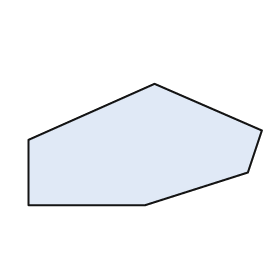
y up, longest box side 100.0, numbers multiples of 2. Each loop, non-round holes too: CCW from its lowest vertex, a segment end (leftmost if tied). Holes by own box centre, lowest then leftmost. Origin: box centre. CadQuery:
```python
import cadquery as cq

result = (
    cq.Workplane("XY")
    .moveTo(-50.0, -26.0)
    .lineTo(0.0, -26.0)
    .lineTo(44.0, -12.0)
    .lineTo(50.0, 6.0)
    .lineTo(4.0, 26.0)
    .lineTo(-50.0, 2.0)
    .close()
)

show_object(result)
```